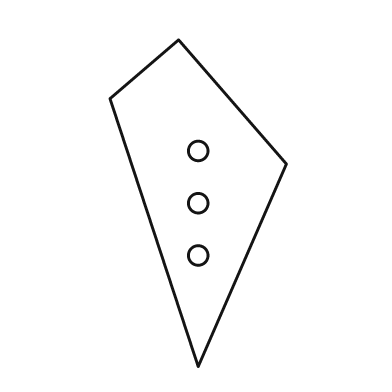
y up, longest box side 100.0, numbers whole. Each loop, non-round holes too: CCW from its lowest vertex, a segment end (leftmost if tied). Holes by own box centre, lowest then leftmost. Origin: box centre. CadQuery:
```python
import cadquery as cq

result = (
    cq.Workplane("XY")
    .moveTo(0.0, -50.0)
    .lineTo(27.0, 12.0)
    .lineTo(-6.0, 50.0)
    .lineTo(-27.0, 32.0)
    .close()
    .moveTo(0.0, -16.0)
    .circle(3.0)
    .moveTo(0.0, 0.0)
    .circle(3.0)
    .moveTo(0.0, 16.0)
    .circle(3.0)
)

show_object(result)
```